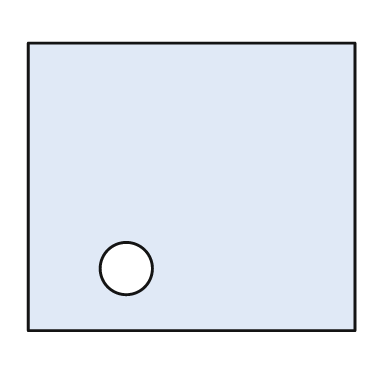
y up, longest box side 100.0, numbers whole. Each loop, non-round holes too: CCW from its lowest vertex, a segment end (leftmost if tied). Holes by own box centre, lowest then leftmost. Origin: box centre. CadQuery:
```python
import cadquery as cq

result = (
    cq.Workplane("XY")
    .moveTo(-50.0, -44.0)
    .lineTo(50.0, -44.0)
    .lineTo(50.0, 44.0)
    .lineTo(-50.0, 44.0)
    .close()
    .moveTo(-20.0, -25.0)
    .circle(8.0)
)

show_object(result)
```